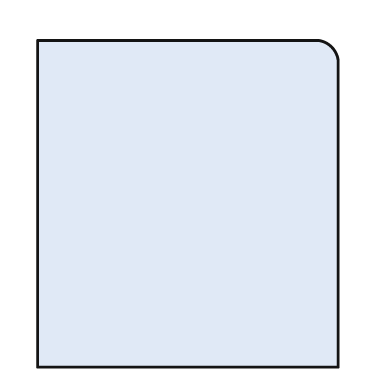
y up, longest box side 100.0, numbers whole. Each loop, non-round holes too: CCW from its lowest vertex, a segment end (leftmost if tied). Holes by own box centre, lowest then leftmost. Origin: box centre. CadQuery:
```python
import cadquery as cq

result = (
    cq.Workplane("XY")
    .moveTo(-46.0, -50.0)
    .lineTo(46.0, -50.0)
    .lineTo(46.0, 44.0)
    .threePointArc((44.0, 48.0), (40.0, 50.0))
    .lineTo(-46.0, 50.0)
    .close()
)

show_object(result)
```